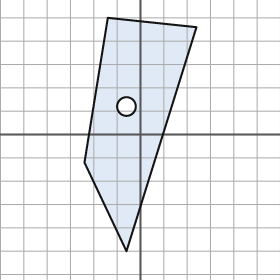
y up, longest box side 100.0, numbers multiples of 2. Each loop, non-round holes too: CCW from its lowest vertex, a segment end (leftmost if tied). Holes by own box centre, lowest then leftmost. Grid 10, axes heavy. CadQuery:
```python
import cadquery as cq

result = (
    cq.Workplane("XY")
    .moveTo(-6.0, -50.0)
    .lineTo(24.0, 46.0)
    .lineTo(-14.0, 50.0)
    .lineTo(-24.0, -12.0)
    .close()
    .moveTo(-6.0, 12.0)
    .circle(4.0)
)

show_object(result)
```